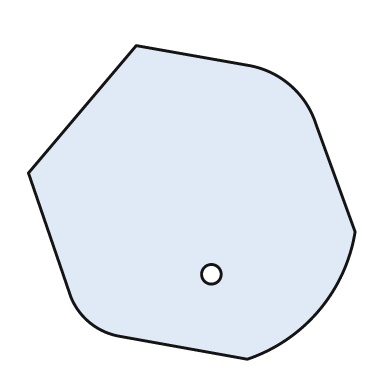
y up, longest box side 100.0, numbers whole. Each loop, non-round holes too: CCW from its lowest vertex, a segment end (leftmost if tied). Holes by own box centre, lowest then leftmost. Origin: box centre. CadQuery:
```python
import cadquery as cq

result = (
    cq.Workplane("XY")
    .moveTo(17.0, -48.0)
    .threePointArc((39.0, -33.0), (50.0, -9.0))
    .lineTo(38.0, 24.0)
    .threePointArc((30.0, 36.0), (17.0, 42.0))
    .lineTo(-17.0, 48.0)
    .lineTo(-50.0, 9.0)
    .lineTo(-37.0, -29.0)
    .threePointArc((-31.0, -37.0), (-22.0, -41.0))
    .close()
    .moveTo(6.0, -22.0)
    .circle(3.0)
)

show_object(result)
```